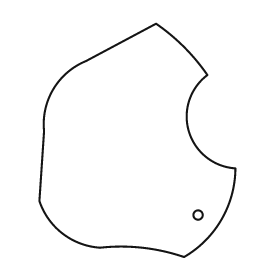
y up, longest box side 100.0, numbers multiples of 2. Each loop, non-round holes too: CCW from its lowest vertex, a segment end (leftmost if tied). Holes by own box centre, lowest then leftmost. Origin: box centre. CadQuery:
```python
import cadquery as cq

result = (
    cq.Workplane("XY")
    .moveTo(20.0, -50.0)
    .threePointArc((36.0, -34.0), (42.0, -12.0))
    .threePointArc((22.0, 4.0), (30.0, 28.0))
    .threePointArc((20.0, 40.0), (8.0, 50.0))
    .lineTo(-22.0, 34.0)
    .threePointArc((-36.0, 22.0), (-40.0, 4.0))
    .lineTo(-42.0, -26.0)
    .threePointArc((-32.0, -40.0), (-16.0, -46.0))
    .threePointArc((2.0, -46.0), (20.0, -50.0))
    .close()
    .moveTo(26.0, -32.0)
    .circle(2.0)
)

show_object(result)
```